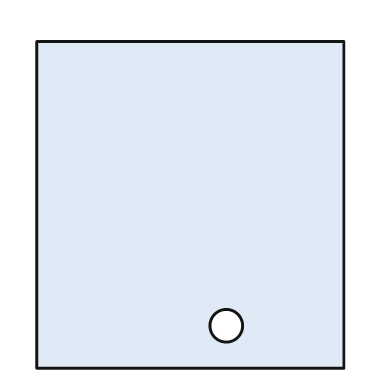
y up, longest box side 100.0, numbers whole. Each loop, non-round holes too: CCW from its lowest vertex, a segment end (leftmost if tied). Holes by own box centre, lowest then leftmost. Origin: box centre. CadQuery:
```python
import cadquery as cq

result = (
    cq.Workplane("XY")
    .moveTo(-47.0, -50.0)
    .lineTo(47.0, -50.0)
    .lineTo(47.0, 50.0)
    .lineTo(-47.0, 50.0)
    .close()
    .moveTo(11.0, -37.0)
    .circle(5.0)
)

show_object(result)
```